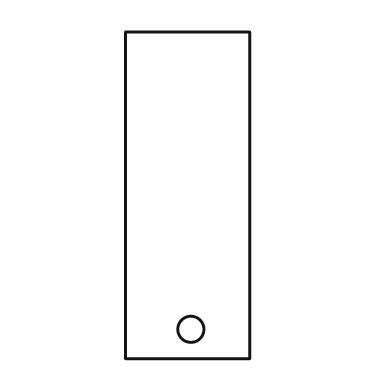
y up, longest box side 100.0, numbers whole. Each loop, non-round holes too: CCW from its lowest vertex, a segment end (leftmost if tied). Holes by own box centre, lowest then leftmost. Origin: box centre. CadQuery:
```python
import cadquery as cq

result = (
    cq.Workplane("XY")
    .moveTo(-19.0, -50.0)
    .lineTo(19.0, -50.0)
    .lineTo(19.0, 50.0)
    .lineTo(-19.0, 50.0)
    .close()
    .moveTo(1.0, -41.0)
    .circle(4.0)
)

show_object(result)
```